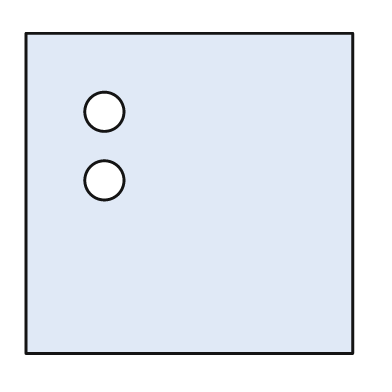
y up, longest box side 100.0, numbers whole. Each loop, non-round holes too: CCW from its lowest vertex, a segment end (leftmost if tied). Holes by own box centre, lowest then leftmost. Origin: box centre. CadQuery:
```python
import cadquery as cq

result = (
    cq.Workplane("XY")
    .moveTo(-50.0, -49.0)
    .lineTo(50.0, -49.0)
    .lineTo(50.0, 49.0)
    .lineTo(-50.0, 49.0)
    .close()
    .moveTo(-26.0, 4.0)
    .circle(6.0)
    .moveTo(-26.0, 25.0)
    .circle(6.0)
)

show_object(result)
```